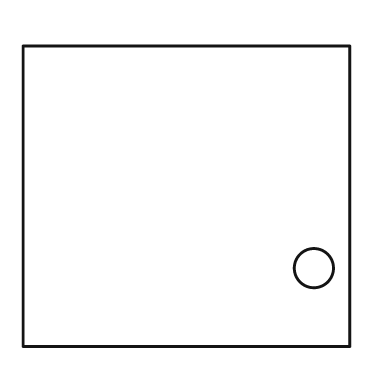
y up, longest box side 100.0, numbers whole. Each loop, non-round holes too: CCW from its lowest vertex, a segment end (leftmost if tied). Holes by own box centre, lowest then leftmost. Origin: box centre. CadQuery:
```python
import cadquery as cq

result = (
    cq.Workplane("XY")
    .moveTo(-50.0, -46.0)
    .lineTo(50.0, -46.0)
    .lineTo(50.0, 46.0)
    .lineTo(-50.0, 46.0)
    .close()
    .moveTo(39.0, -22.0)
    .circle(6.0)
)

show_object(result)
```